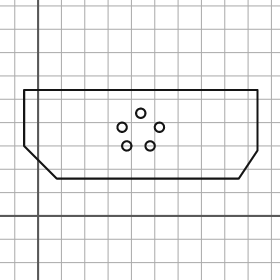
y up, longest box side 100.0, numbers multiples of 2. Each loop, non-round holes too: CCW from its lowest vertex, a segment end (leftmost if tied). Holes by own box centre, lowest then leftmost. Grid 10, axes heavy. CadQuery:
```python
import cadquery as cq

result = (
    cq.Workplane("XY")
    .moveTo(8.0, 16.0)
    .lineTo(86.0, 16.0)
    .lineTo(94.0, 28.0)
    .lineTo(94.0, 54.0)
    .lineTo(-6.0, 54.0)
    .lineTo(-6.0, 30.0)
    .close()
    .moveTo(38.0, 30.0)
    .circle(2.0)
    .moveTo(48.0, 30.0)
    .circle(2.0)
    .moveTo(36.0, 38.0)
    .circle(2.0)
    .moveTo(52.0, 38.0)
    .circle(2.0)
    .moveTo(44.0, 44.0)
    .circle(2.0)
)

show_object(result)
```